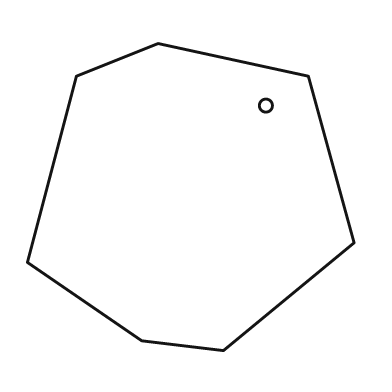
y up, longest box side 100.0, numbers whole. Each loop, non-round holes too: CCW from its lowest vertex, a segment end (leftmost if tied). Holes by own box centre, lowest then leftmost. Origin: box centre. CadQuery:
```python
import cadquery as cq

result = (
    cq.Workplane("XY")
    .moveTo(10.0, -47.0)
    .lineTo(50.0, -14.0)
    .lineTo(36.0, 37.0)
    .lineTo(-10.0, 47.0)
    .lineTo(-35.0, 37.0)
    .lineTo(-50.0, -20.0)
    .lineTo(-15.0, -44.0)
    .close()
    .moveTo(23.0, 28.0)
    .circle(2.0)
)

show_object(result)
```